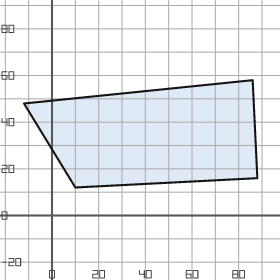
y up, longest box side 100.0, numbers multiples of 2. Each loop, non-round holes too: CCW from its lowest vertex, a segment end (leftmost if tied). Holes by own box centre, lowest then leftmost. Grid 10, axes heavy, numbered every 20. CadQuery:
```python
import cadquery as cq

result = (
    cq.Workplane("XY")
    .moveTo(10.0, 12.0)
    .lineTo(88.0, 16.0)
    .lineTo(86.0, 58.0)
    .lineTo(-12.0, 48.0)
    .close()
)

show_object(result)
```